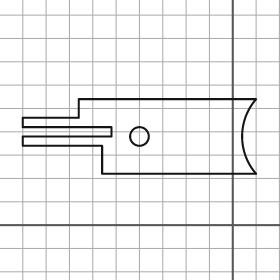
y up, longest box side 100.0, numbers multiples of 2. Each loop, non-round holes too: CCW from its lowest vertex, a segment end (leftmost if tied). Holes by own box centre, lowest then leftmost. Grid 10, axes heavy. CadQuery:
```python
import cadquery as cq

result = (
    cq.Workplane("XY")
    .moveTo(-56.0, 22.0)
    .lineTo(10.0, 22.0)
    .threePointArc((4.0, 38.0), (10.0, 54.0))
    .lineTo(-66.0, 54.0)
    .lineTo(-66.0, 46.0)
    .lineTo(-90.0, 46.0)
    .lineTo(-90.0, 42.0)
    .lineTo(-52.0, 42.0)
    .lineTo(-52.0, 38.0)
    .lineTo(-90.0, 38.0)
    .lineTo(-90.0, 34.0)
    .lineTo(-56.0, 34.0)
    .close()
    .moveTo(-40.0, 38.0)
    .circle(4.0)
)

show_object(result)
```